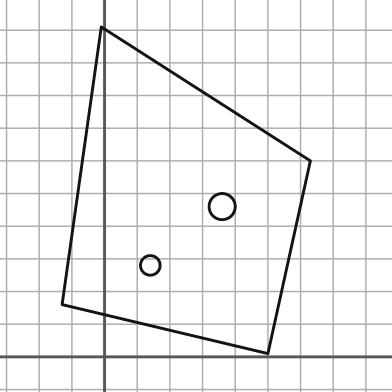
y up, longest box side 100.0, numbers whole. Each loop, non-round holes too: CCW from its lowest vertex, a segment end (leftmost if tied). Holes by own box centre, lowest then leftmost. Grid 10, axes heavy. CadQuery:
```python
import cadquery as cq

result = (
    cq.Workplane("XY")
    .moveTo(50.0, 1.0)
    .lineTo(63.0, 60.0)
    .lineTo(-1.0, 101.0)
    .lineTo(-13.0, 16.0)
    .close()
    .moveTo(14.0, 28.0)
    .circle(3.0)
    .moveTo(36.0, 46.0)
    .circle(4.0)
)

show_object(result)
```